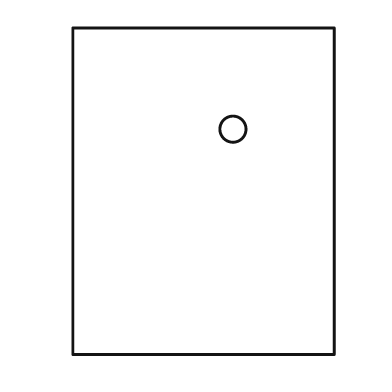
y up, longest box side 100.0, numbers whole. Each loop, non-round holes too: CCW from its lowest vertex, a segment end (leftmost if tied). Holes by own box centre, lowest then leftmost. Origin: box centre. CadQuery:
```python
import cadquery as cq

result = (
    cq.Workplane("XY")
    .moveTo(-40.0, -50.0)
    .lineTo(40.0, -50.0)
    .lineTo(40.0, 50.0)
    .lineTo(-40.0, 50.0)
    .close()
    .moveTo(9.0, 19.0)
    .circle(4.0)
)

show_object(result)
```